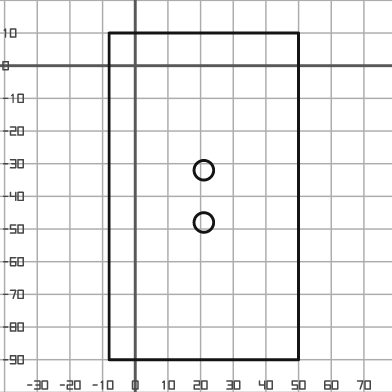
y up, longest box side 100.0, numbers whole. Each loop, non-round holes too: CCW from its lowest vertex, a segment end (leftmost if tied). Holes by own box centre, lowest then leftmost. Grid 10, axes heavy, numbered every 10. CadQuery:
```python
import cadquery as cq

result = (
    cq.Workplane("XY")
    .moveTo(-8.0, -90.0)
    .lineTo(50.0, -90.0)
    .lineTo(50.0, 10.0)
    .lineTo(-8.0, 10.0)
    .close()
    .moveTo(21.0, -48.0)
    .circle(3.0)
    .moveTo(21.0, -32.0)
    .circle(3.0)
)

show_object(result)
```